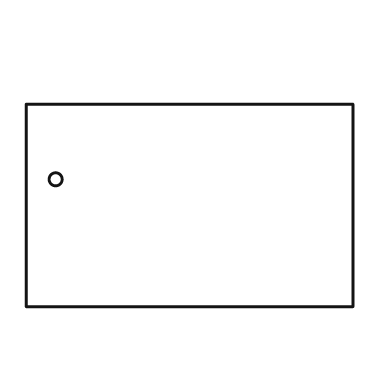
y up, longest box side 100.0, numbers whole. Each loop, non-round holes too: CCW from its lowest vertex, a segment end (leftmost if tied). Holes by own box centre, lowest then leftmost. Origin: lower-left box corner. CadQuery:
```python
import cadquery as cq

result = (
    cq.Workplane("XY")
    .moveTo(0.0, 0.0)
    .lineTo(100.0, 0.0)
    .lineTo(100.0, 62.0)
    .lineTo(0.0, 62.0)
    .close()
    .moveTo(9.0, 39.0)
    .circle(2.0)
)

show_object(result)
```